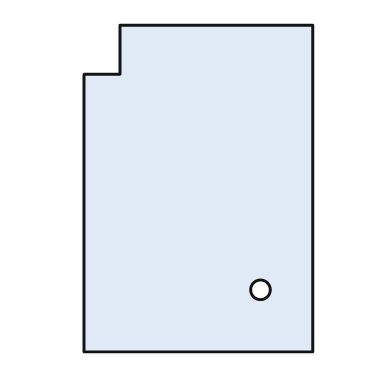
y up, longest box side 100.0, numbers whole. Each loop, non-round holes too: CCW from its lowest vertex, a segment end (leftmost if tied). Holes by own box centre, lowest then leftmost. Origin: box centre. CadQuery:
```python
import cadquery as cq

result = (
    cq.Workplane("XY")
    .moveTo(-35.0, -50.0)
    .lineTo(35.0, -50.0)
    .lineTo(35.0, 50.0)
    .lineTo(-24.0, 50.0)
    .lineTo(-24.0, 35.0)
    .lineTo(-35.0, 35.0)
    .close()
    .moveTo(19.0, -31.0)
    .circle(3.0)
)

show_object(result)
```